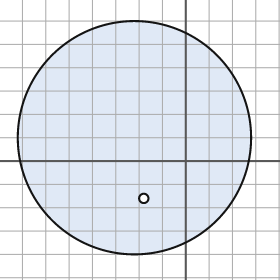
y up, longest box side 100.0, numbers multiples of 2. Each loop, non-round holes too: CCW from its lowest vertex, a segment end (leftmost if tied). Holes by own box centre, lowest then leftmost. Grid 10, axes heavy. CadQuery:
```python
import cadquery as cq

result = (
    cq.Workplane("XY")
    .moveTo(-22.0, 10.0)
    .circle(50.0)
    .moveTo(-18.0, -16.0)
    .circle(2.0)
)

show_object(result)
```